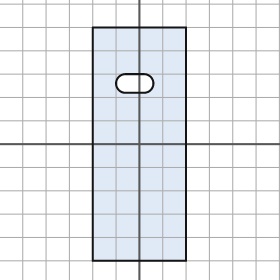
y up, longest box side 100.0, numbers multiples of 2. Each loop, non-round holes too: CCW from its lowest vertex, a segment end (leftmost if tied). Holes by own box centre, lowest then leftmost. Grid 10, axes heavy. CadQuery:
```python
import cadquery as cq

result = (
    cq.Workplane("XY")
    .moveTo(-20.0, -50.0)
    .lineTo(20.0, -50.0)
    .lineTo(20.0, 50.0)
    .lineTo(-20.0, 50.0)
    .close()
    .moveTo(-6.0, 22.0)
    .lineTo(2.0, 22.0)
    .threePointArc((6.0, 26.0), (2.0, 30.0))
    .lineTo(-6.0, 30.0)
    .threePointArc((-10.0, 26.0), (-6.0, 22.0))
    .close()
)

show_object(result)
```